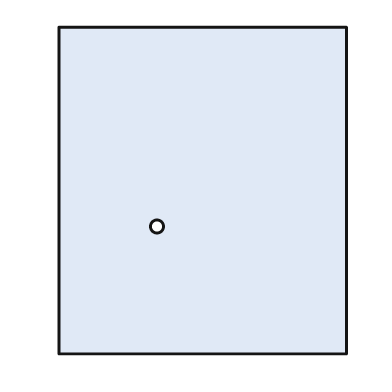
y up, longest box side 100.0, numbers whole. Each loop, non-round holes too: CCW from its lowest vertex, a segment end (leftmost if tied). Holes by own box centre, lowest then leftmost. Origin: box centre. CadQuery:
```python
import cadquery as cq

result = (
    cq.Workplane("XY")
    .moveTo(-44.0, -50.0)
    .lineTo(44.0, -50.0)
    .lineTo(44.0, 50.0)
    .lineTo(-44.0, 50.0)
    .close()
    .moveTo(-14.0, -11.0)
    .circle(2.0)
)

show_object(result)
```